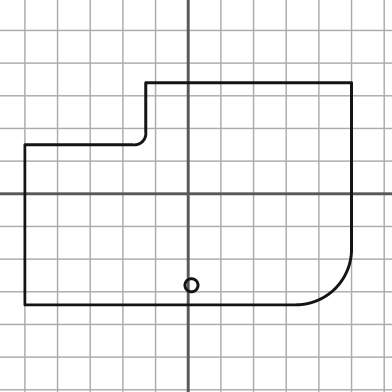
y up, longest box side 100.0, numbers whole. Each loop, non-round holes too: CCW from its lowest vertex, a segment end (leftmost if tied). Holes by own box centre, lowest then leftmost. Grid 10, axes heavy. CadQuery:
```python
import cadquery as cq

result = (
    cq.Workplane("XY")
    .moveTo(-50.0, -34.0)
    .lineTo(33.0, -34.0)
    .threePointArc((45.0, -29.0), (50.0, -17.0))
    .lineTo(50.0, 34.0)
    .lineTo(-13.0, 34.0)
    .lineTo(-13.0, 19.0)
    .threePointArc((-14.0, 16.0), (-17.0, 15.0))
    .lineTo(-50.0, 15.0)
    .close()
    .moveTo(1.0, -28.0)
    .circle(2.0)
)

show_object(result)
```